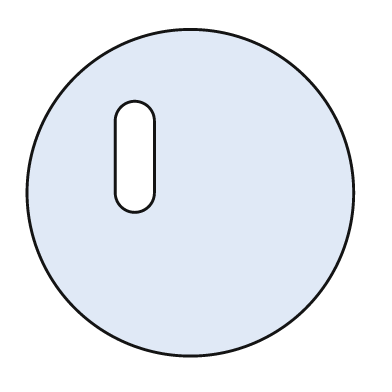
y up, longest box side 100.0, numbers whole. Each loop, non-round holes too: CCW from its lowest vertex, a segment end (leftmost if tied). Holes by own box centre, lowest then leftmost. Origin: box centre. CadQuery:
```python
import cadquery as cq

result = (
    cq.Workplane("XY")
    .moveTo(0.0, 0.0)
    .circle(50.0)
    .moveTo(-23.0, 0.0)
    .threePointArc((-17.0, -6.0), (-11.0, 0.0))
    .lineTo(-11.0, 22.0)
    .threePointArc((-17.0, 28.0), (-23.0, 22.0))
    .close()
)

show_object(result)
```